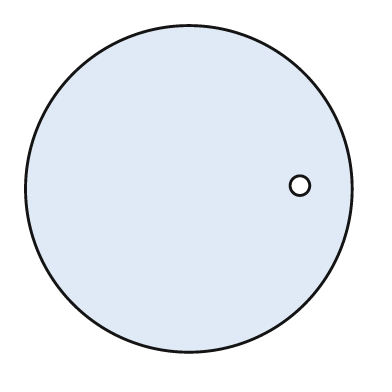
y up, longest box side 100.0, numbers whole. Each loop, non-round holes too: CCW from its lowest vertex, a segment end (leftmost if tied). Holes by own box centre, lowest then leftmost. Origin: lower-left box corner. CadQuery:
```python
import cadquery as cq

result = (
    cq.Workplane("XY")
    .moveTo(50.0, 50.0)
    .circle(50.0)
    .moveTo(84.0, 51.0)
    .circle(3.0)
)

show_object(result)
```